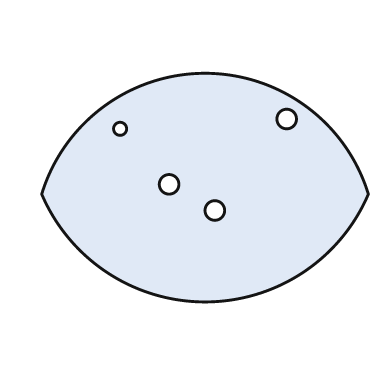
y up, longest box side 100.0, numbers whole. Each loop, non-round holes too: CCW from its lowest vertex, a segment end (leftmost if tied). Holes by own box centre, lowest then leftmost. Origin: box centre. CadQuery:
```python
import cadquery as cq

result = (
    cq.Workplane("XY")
    .moveTo(-50.0, -2.0)
    .threePointArc((0.0, -35.0), (50.0, -2.0))
    .threePointArc((0.0, 35.0), (-50.0, -2.0))
    .close()
    .moveTo(3.0, -7.0)
    .circle(3.0)
    .moveTo(-11.0, 1.0)
    .circle(3.0)
    .moveTo(-26.0, 18.0)
    .circle(2.0)
    .moveTo(25.0, 21.0)
    .circle(3.0)
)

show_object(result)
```